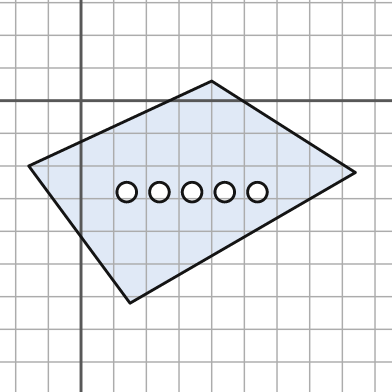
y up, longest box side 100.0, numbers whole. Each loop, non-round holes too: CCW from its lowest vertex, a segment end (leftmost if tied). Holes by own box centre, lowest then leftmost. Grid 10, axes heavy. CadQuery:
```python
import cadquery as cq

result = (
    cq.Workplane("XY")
    .moveTo(15.0, -62.0)
    .lineTo(84.0, -22.0)
    .lineTo(40.0, 6.0)
    .lineTo(-16.0, -20.0)
    .close()
    .moveTo(14.0, -28.0)
    .circle(3.0)
    .moveTo(24.0, -28.0)
    .circle(3.0)
    .moveTo(34.0, -28.0)
    .circle(3.0)
    .moveTo(44.0, -28.0)
    .circle(3.0)
    .moveTo(54.0, -28.0)
    .circle(3.0)
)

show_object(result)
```